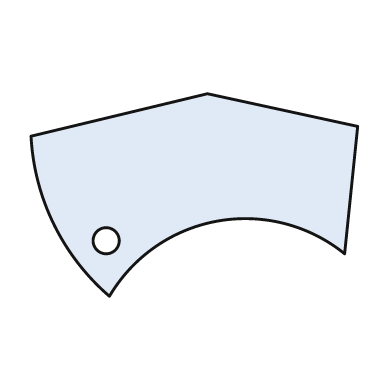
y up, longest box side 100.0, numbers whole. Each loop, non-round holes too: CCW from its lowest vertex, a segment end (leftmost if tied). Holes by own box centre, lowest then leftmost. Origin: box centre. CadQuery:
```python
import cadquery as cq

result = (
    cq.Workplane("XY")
    .moveTo(-26.0, -31.0)
    .threePointArc((7.0, -8.0), (46.0, -18.0))
    .lineTo(50.0, 21.0)
    .lineTo(4.0, 31.0)
    .lineTo(-50.0, 18.0)
    .threePointArc((-43.0, -9.0), (-26.0, -31.0))
    .close()
    .moveTo(-27.0, -14.0)
    .circle(4.0)
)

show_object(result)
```